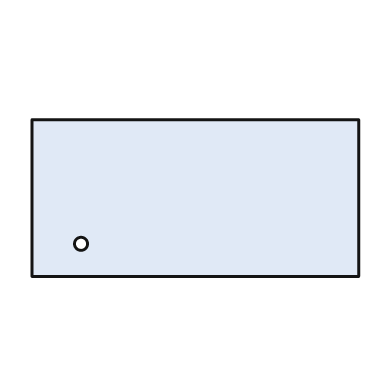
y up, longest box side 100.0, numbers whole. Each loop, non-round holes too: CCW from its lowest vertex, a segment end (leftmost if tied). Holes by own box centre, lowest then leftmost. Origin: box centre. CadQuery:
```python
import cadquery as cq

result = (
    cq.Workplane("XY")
    .moveTo(-50.0, -24.0)
    .lineTo(50.0, -24.0)
    .lineTo(50.0, 24.0)
    .lineTo(-50.0, 24.0)
    .close()
    .moveTo(-35.0, -14.0)
    .circle(2.0)
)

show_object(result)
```